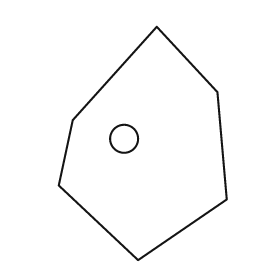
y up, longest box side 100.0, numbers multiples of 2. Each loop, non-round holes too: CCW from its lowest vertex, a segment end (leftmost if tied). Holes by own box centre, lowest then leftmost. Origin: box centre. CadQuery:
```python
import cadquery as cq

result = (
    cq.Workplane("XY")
    .moveTo(-2.0, -50.0)
    .lineTo(36.0, -24.0)
    .lineTo(32.0, 22.0)
    .lineTo(6.0, 50.0)
    .lineTo(-30.0, 10.0)
    .lineTo(-36.0, -18.0)
    .close()
    .moveTo(-8.0, 2.0)
    .circle(6.0)
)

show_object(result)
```